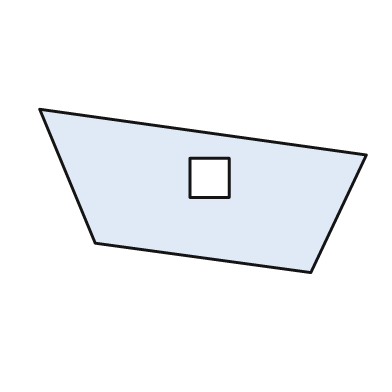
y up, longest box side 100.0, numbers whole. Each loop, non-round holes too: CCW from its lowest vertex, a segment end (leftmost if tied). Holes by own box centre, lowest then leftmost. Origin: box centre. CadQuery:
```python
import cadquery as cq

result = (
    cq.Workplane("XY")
    .moveTo(33.0, -25.0)
    .lineTo(50.0, 11.0)
    .lineTo(-50.0, 25.0)
    .lineTo(-33.0, -16.0)
    .close()
    .moveTo(-4.0, -2.0)
    .lineTo(8.0, -2.0)
    .lineTo(8.0, 10.0)
    .lineTo(-4.0, 10.0)
    .close()
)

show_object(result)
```